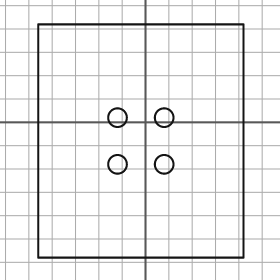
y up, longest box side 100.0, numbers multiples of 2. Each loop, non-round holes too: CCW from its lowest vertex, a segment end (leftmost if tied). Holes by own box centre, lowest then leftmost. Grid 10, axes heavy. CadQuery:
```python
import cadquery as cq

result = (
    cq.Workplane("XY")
    .moveTo(-46.0, -58.0)
    .lineTo(42.0, -58.0)
    .lineTo(42.0, 42.0)
    .lineTo(-46.0, 42.0)
    .close()
    .moveTo(-12.0, -18.0)
    .circle(4.0)
    .moveTo(8.0, -18.0)
    .circle(4.0)
    .moveTo(-12.0, 2.0)
    .circle(4.0)
    .moveTo(8.0, 2.0)
    .circle(4.0)
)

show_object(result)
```